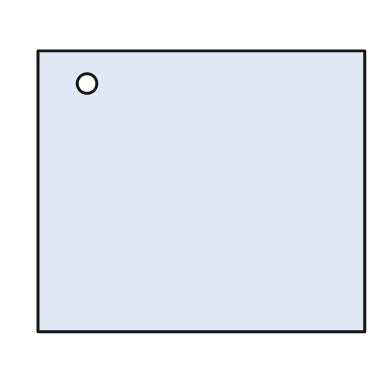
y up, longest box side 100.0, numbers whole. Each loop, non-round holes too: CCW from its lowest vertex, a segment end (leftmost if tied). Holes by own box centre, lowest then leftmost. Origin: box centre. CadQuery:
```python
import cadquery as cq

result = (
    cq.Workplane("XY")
    .moveTo(-50.0, -43.0)
    .lineTo(50.0, -43.0)
    .lineTo(50.0, 43.0)
    .lineTo(-50.0, 43.0)
    .close()
    .moveTo(-35.0, 33.0)
    .circle(3.0)
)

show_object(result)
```